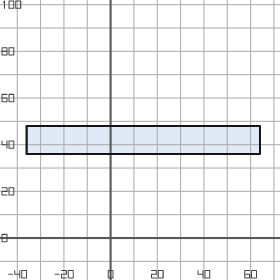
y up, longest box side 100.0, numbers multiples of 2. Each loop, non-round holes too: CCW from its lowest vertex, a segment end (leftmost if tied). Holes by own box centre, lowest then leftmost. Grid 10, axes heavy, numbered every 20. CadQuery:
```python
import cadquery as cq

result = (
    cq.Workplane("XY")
    .moveTo(-36.0, 36.0)
    .lineTo(64.0, 36.0)
    .lineTo(64.0, 48.0)
    .lineTo(-36.0, 48.0)
    .close()
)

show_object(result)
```